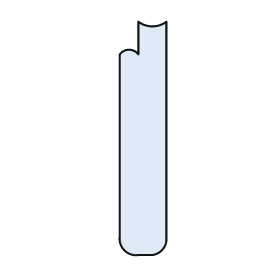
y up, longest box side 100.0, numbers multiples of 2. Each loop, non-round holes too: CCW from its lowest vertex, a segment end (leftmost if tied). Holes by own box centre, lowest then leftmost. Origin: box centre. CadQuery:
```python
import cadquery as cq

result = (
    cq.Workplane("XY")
    .moveTo(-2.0, -50.0)
    .lineTo(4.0, -50.0)
    .threePointArc((8.0, -48.0), (10.0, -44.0))
    .lineTo(10.0, 50.0)
    .threePointArc((4.0, 48.0), (-2.0, 50.0))
    .lineTo(-2.0, 36.0)
    .threePointArc((-6.0, 38.0), (-10.0, 36.0))
    .lineTo(-10.0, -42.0)
    .threePointArc((-8.0, -48.0), (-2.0, -50.0))
    .close()
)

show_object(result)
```